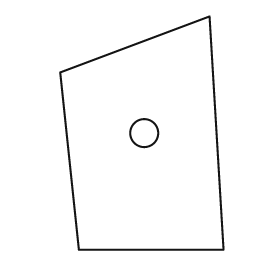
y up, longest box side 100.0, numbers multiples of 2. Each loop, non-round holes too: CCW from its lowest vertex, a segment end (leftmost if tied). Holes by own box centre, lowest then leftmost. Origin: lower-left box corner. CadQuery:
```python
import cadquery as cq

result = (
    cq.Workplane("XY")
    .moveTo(8.0, 0.0)
    .lineTo(70.0, 0.0)
    .lineTo(64.0, 100.0)
    .lineTo(0.0, 76.0)
    .close()
    .moveTo(36.0, 50.0)
    .circle(6.0)
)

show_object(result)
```